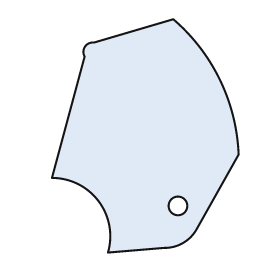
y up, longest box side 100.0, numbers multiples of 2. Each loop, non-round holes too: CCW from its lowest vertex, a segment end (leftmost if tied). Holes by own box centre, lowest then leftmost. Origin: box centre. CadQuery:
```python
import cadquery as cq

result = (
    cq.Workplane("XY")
    .moveTo(-16.0, -50.0)
    .lineTo(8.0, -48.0)
    .threePointArc((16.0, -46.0), (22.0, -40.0))
    .lineTo(40.0, -8.0)
    .threePointArc((32.0, 24.0), (12.0, 50.0))
    .lineTo(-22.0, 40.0)
    .threePointArc((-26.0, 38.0), (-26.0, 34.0))
    .lineTo(-40.0, -18.0)
    .threePointArc((-20.0, -28.0), (-16.0, -50.0))
    .close()
    .moveTo(14.0, -30.0)
    .circle(4.0)
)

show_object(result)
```